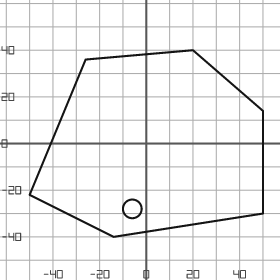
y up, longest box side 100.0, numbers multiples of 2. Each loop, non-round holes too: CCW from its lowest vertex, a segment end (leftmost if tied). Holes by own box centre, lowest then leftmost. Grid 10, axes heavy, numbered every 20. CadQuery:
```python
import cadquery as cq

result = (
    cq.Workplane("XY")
    .moveTo(-14.0, -40.0)
    .lineTo(50.0, -30.0)
    .lineTo(50.0, 14.0)
    .lineTo(20.0, 40.0)
    .lineTo(-26.0, 36.0)
    .lineTo(-50.0, -22.0)
    .close()
    .moveTo(-6.0, -28.0)
    .circle(4.0)
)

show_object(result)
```